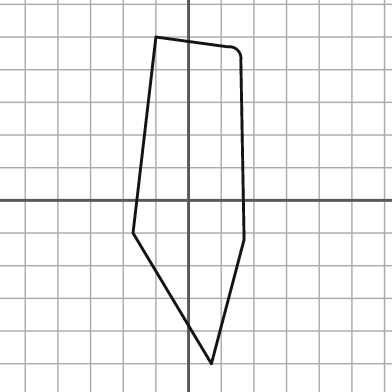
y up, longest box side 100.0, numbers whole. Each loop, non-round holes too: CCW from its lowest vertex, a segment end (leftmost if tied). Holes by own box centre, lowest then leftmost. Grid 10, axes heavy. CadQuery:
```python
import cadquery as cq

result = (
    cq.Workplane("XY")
    .moveTo(7.0, -50.0)
    .lineTo(17.0, -12.0)
    .lineTo(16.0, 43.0)
    .threePointArc((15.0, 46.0), (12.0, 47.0))
    .lineTo(-10.0, 50.0)
    .lineTo(-17.0, -10.0)
    .close()
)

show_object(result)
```